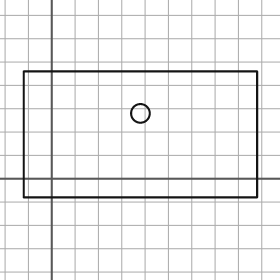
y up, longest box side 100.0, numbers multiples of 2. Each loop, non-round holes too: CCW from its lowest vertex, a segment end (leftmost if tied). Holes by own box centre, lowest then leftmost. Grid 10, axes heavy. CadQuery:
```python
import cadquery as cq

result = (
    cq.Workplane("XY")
    .moveTo(-12.0, -8.0)
    .lineTo(88.0, -8.0)
    .lineTo(88.0, 46.0)
    .lineTo(-12.0, 46.0)
    .close()
    .moveTo(38.0, 28.0)
    .circle(4.0)
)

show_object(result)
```